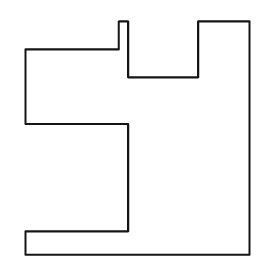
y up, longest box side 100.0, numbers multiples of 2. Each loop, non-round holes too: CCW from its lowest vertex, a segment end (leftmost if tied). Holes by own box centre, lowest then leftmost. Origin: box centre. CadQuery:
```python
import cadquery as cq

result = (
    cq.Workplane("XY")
    .moveTo(-48.0, -50.0)
    .lineTo(48.0, -50.0)
    .lineTo(48.0, 50.0)
    .lineTo(26.0, 50.0)
    .lineTo(26.0, 26.0)
    .lineTo(-4.0, 26.0)
    .lineTo(-4.0, 50.0)
    .lineTo(-8.0, 50.0)
    .lineTo(-8.0, 38.0)
    .lineTo(-48.0, 38.0)
    .lineTo(-48.0, 6.0)
    .lineTo(-4.0, 6.0)
    .lineTo(-4.0, -40.0)
    .lineTo(-48.0, -40.0)
    .close()
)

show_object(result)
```